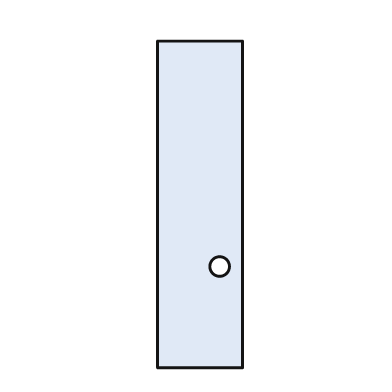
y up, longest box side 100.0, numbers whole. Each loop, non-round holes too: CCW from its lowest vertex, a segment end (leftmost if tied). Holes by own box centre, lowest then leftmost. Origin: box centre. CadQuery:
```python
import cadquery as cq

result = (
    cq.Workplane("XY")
    .moveTo(-13.0, -50.0)
    .lineTo(13.0, -50.0)
    .lineTo(13.0, 50.0)
    .lineTo(-13.0, 50.0)
    .close()
    .moveTo(6.0, -19.0)
    .circle(3.0)
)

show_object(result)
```